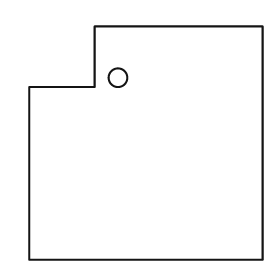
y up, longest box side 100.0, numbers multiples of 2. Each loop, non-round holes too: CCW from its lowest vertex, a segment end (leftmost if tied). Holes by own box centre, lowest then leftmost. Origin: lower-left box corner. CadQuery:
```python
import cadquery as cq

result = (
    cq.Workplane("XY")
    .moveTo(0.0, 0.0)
    .lineTo(100.0, 0.0)
    .lineTo(100.0, 100.0)
    .lineTo(28.0, 100.0)
    .lineTo(28.0, 74.0)
    .lineTo(0.0, 74.0)
    .close()
    .moveTo(38.0, 78.0)
    .circle(4.0)
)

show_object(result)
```